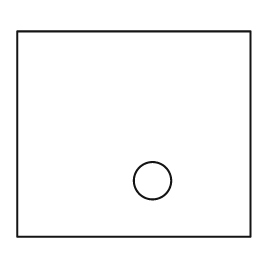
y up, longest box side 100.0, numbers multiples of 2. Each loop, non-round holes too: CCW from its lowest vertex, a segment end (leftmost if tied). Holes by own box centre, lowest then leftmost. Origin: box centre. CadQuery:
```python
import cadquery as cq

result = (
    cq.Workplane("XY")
    .moveTo(-50.0, -44.0)
    .lineTo(50.0, -44.0)
    .lineTo(50.0, 44.0)
    .lineTo(-50.0, 44.0)
    .close()
    .moveTo(8.0, -20.0)
    .circle(8.0)
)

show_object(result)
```